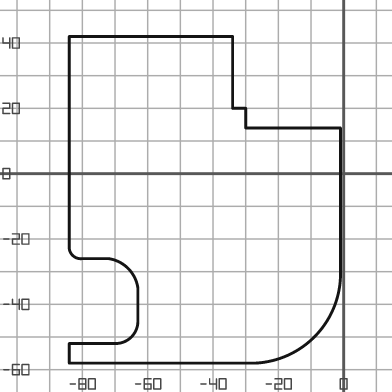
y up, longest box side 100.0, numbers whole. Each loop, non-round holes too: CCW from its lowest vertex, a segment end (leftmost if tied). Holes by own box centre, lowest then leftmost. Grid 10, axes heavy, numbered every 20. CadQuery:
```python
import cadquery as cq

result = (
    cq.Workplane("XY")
    .moveTo(-84.0, -58.0)
    .lineTo(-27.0, -58.0)
    .threePointArc((-9.0, -50.0), (-1.0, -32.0))
    .lineTo(-1.0, 14.0)
    .lineTo(-30.0, 14.0)
    .lineTo(-30.0, 20.0)
    .lineTo(-34.0, 20.0)
    .lineTo(-34.0, 42.0)
    .lineTo(-84.0, 42.0)
    .lineTo(-84.0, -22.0)
    .threePointArc((-83.0, -25.0), (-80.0, -26.0))
    .lineTo(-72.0, -26.0)
    .threePointArc((-66.0, -29.0), (-63.0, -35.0))
    .lineTo(-63.0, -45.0)
    .threePointArc((-65.0, -50.0), (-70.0, -52.0))
    .lineTo(-84.0, -52.0)
    .close()
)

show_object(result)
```